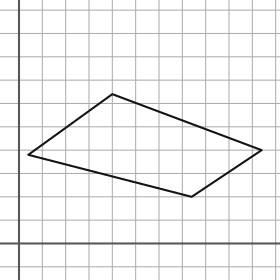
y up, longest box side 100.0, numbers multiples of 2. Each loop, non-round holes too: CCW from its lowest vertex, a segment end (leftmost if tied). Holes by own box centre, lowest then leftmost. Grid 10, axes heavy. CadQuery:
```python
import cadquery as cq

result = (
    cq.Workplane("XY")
    .moveTo(74.0, 20.0)
    .lineTo(104.0, 40.0)
    .lineTo(40.0, 64.0)
    .lineTo(4.0, 38.0)
    .close()
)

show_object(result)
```